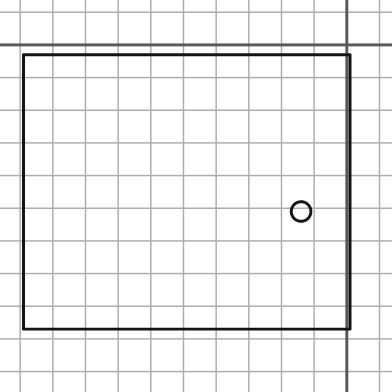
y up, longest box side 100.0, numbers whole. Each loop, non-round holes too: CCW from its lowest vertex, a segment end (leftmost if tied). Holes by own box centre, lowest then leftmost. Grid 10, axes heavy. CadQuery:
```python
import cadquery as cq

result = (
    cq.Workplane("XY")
    .moveTo(-99.0, -87.0)
    .lineTo(1.0, -87.0)
    .lineTo(1.0, -3.0)
    .lineTo(-99.0, -3.0)
    .close()
    .moveTo(-14.0, -51.0)
    .circle(3.0)
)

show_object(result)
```